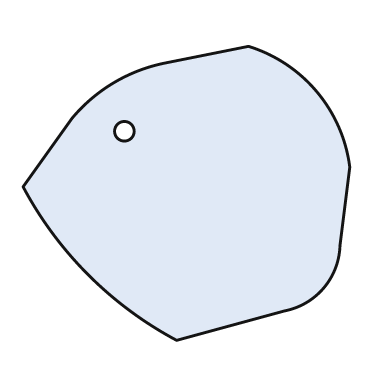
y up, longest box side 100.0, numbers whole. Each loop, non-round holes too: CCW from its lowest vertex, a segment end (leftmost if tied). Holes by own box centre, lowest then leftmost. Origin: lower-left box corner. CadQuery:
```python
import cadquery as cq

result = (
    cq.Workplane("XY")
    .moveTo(47.0, 0.0)
    .lineTo(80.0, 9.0)
    .threePointArc((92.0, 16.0), (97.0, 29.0))
    .lineTo(100.0, 53.0)
    .threePointArc((90.0, 76.0), (69.0, 90.0))
    .lineTo(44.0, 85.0)
    .threePointArc((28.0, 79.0), (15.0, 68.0))
    .lineTo(0.0, 47.0)
    .threePointArc((20.0, 20.0), (47.0, 0.0))
    .close()
    .moveTo(31.0, 64.0)
    .circle(3.0)
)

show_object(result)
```